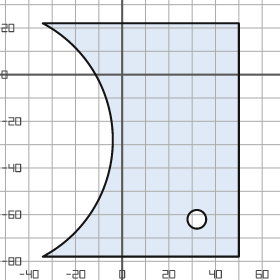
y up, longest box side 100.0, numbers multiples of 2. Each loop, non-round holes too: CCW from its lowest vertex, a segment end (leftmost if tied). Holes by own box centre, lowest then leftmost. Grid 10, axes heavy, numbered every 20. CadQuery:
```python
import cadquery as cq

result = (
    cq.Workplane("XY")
    .moveTo(-34.0, -78.0)
    .lineTo(50.0, -78.0)
    .lineTo(50.0, 22.0)
    .lineTo(-34.0, 22.0)
    .threePointArc((-4.0, -28.0), (-34.0, -78.0))
    .close()
    .moveTo(32.0, -62.0)
    .circle(4.0)
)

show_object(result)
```